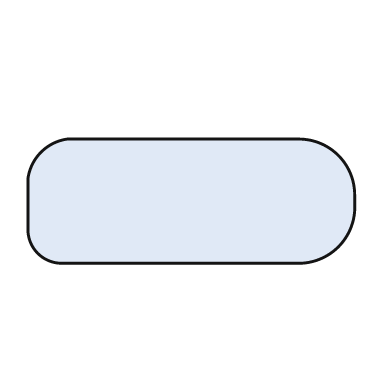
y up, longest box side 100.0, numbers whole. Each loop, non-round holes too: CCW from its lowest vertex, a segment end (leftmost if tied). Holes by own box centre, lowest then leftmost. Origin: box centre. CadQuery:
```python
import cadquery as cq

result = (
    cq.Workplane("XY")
    .moveTo(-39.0, -19.0)
    .lineTo(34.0, -19.0)
    .threePointArc((45.0, -14.0), (50.0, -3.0))
    .lineTo(50.0, 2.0)
    .threePointArc((45.0, 14.0), (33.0, 19.0))
    .lineTo(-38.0, 19.0)
    .threePointArc((-46.0, 15.0), (-50.0, 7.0))
    .lineTo(-50.0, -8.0)
    .threePointArc((-47.0, -16.0), (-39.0, -19.0))
    .close()
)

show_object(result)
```